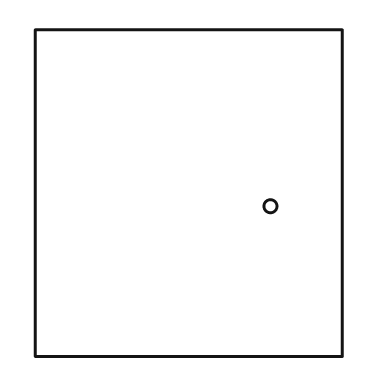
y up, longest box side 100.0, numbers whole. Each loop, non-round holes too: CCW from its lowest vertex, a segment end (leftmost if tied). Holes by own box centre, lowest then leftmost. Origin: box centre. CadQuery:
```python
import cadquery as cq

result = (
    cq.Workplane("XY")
    .moveTo(-47.0, -50.0)
    .lineTo(47.0, -50.0)
    .lineTo(47.0, 50.0)
    .lineTo(-47.0, 50.0)
    .close()
    .moveTo(25.0, -4.0)
    .circle(2.0)
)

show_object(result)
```